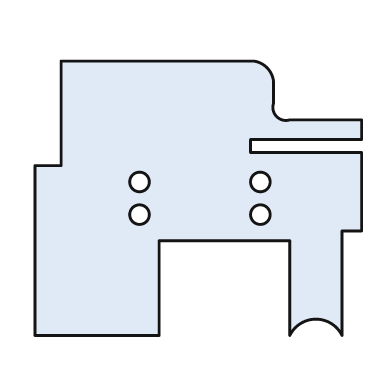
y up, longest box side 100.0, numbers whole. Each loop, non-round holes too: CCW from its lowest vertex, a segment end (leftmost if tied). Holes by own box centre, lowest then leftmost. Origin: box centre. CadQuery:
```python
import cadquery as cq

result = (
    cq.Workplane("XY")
    .moveTo(-50.0, -42.0)
    .lineTo(-12.0, -42.0)
    .lineTo(-12.0, -13.0)
    .lineTo(28.0, -13.0)
    .lineTo(28.0, -42.0)
    .threePointArc((36.0, -37.0), (44.0, -42.0))
    .lineTo(44.0, -10.0)
    .lineTo(50.0, -10.0)
    .lineTo(50.0, 14.0)
    .lineTo(16.0, 14.0)
    .lineTo(16.0, 18.0)
    .lineTo(50.0, 18.0)
    .lineTo(50.0, 24.0)
    .lineTo(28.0, 24.0)
    .threePointArc((24.0, 25.0), (23.0, 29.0))
    .lineTo(23.0, 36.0)
    .threePointArc((21.0, 40.0), (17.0, 42.0))
    .lineTo(-42.0, 42.0)
    .lineTo(-42.0, 10.0)
    .lineTo(-50.0, 10.0)
    .close()
    .moveTo(-18.0, -5.0)
    .circle(3.0)
    .moveTo(19.0, -5.0)
    .circle(3.0)
    .moveTo(-18.0, 5.0)
    .circle(3.0)
    .moveTo(19.0, 5.0)
    .circle(3.0)
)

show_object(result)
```